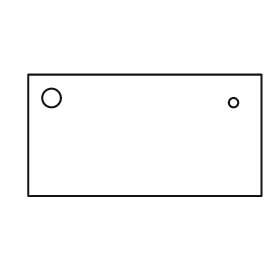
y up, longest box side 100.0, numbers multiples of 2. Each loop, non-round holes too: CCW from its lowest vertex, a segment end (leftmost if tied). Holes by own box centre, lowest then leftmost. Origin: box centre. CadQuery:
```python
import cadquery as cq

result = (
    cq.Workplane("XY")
    .moveTo(-50.0, -26.0)
    .lineTo(50.0, -26.0)
    .lineTo(50.0, 26.0)
    .lineTo(-50.0, 26.0)
    .close()
    .moveTo(38.0, 14.0)
    .circle(2.0)
    .moveTo(-40.0, 16.0)
    .circle(4.0)
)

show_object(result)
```